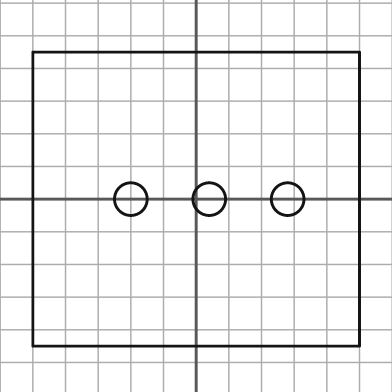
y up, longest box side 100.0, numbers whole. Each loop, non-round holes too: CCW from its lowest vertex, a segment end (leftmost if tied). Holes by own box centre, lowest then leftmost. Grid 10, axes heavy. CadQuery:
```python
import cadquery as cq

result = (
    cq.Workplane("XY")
    .moveTo(-50.0, -45.0)
    .lineTo(50.0, -45.0)
    .lineTo(50.0, 45.0)
    .lineTo(-50.0, 45.0)
    .close()
    .moveTo(-20.0, 0.0)
    .circle(5.0)
    .moveTo(4.0, 0.0)
    .circle(5.0)
    .moveTo(28.0, 0.0)
    .circle(5.0)
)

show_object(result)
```